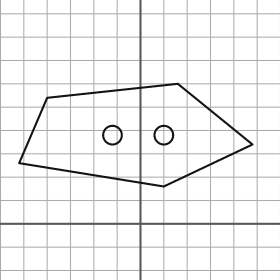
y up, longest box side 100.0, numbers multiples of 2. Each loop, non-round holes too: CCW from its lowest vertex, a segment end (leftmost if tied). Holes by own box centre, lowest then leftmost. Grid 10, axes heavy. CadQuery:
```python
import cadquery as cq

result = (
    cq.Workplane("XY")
    .moveTo(10.0, 16.0)
    .lineTo(48.0, 34.0)
    .lineTo(16.0, 60.0)
    .lineTo(-40.0, 54.0)
    .lineTo(-52.0, 26.0)
    .close()
    .moveTo(-12.0, 38.0)
    .circle(4.0)
    .moveTo(10.0, 38.0)
    .circle(4.0)
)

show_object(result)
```